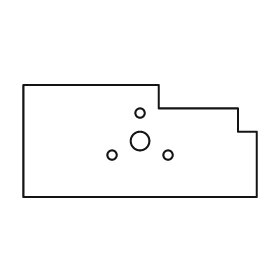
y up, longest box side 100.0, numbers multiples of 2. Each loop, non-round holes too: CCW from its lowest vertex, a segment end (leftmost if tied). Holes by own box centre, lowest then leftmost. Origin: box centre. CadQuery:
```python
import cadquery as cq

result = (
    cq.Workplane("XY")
    .moveTo(-50.0, -24.0)
    .lineTo(50.0, -24.0)
    .lineTo(50.0, 4.0)
    .lineTo(42.0, 4.0)
    .lineTo(42.0, 14.0)
    .lineTo(8.0, 14.0)
    .lineTo(8.0, 24.0)
    .lineTo(-50.0, 24.0)
    .close()
    .moveTo(-12.0, -6.0)
    .circle(2.0)
    .moveTo(12.0, -6.0)
    .circle(2.0)
    .moveTo(0.0, 0.0)
    .circle(4.0)
    .moveTo(0.0, 12.0)
    .circle(2.0)
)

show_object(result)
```